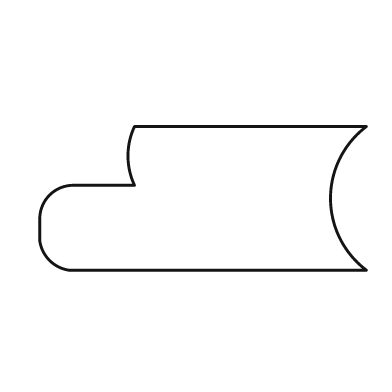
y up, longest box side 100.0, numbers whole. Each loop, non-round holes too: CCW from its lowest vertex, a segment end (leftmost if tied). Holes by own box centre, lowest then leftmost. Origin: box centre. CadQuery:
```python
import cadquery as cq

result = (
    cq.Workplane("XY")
    .moveTo(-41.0, -22.0)
    .lineTo(50.0, -22.0)
    .threePointArc((39.0, 0.0), (50.0, 22.0))
    .lineTo(-21.0, 22.0)
    .threePointArc((-23.0, 13.0), (-21.0, 4.0))
    .lineTo(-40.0, 4.0)
    .threePointArc((-47.0, 1.0), (-50.0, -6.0))
    .lineTo(-50.0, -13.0)
    .threePointArc((-47.0, -19.0), (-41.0, -22.0))
    .close()
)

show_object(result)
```